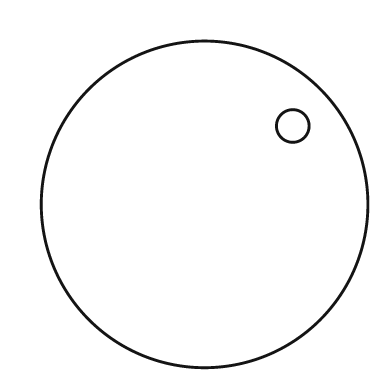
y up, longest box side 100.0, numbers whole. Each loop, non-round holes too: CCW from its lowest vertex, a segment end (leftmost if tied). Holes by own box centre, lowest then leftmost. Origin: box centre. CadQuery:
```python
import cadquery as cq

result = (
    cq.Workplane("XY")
    .moveTo(0.0, 0.0)
    .circle(50.0)
    .moveTo(27.0, 24.0)
    .circle(5.0)
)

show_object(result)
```